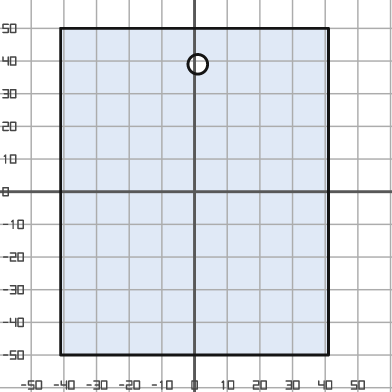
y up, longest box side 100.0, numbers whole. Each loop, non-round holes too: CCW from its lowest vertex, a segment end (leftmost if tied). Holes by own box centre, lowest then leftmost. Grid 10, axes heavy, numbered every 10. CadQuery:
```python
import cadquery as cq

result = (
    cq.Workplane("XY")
    .moveTo(-41.0, -50.0)
    .lineTo(41.0, -50.0)
    .lineTo(41.0, 50.0)
    .lineTo(-41.0, 50.0)
    .close()
    .moveTo(1.0, 39.0)
    .circle(3.0)
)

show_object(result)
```